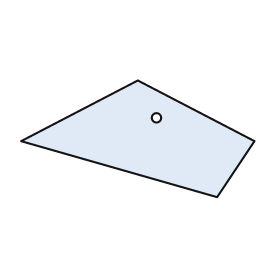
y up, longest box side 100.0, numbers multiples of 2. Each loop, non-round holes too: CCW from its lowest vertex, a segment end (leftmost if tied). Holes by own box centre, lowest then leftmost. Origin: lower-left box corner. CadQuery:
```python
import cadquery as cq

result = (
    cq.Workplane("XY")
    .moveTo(84.0, 0.0)
    .lineTo(100.0, 24.0)
    .lineTo(50.0, 50.0)
    .lineTo(0.0, 24.0)
    .close()
    .moveTo(58.0, 34.0)
    .circle(2.0)
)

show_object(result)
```